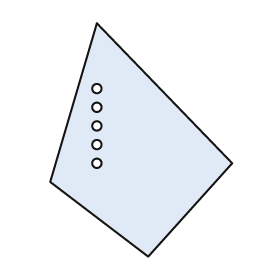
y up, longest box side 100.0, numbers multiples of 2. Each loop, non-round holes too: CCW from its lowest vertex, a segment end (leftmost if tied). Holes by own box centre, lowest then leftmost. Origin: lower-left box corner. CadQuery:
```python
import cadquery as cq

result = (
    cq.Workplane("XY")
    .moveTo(42.0, 0.0)
    .lineTo(78.0, 40.0)
    .lineTo(20.0, 100.0)
    .lineTo(0.0, 32.0)
    .close()
    .moveTo(20.0, 40.0)
    .circle(2.0)
    .moveTo(20.0, 48.0)
    .circle(2.0)
    .moveTo(20.0, 56.0)
    .circle(2.0)
    .moveTo(20.0, 64.0)
    .circle(2.0)
    .moveTo(20.0, 72.0)
    .circle(2.0)
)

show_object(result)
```